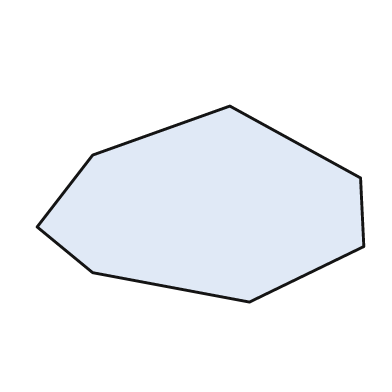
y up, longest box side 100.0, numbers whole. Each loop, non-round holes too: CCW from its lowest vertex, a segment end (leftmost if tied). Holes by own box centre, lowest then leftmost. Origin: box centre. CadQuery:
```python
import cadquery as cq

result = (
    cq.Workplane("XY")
    .moveTo(15.0, -30.0)
    .lineTo(50.0, -13.0)
    .lineTo(49.0, 8.0)
    .lineTo(9.0, 30.0)
    .lineTo(-33.0, 15.0)
    .lineTo(-50.0, -7.0)
    .lineTo(-33.0, -21.0)
    .close()
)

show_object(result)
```